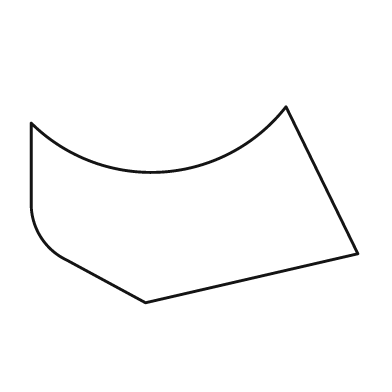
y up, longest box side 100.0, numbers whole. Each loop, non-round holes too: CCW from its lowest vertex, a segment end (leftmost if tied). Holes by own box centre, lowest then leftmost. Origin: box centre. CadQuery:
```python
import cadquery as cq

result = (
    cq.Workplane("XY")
    .moveTo(-15.0, -30.0)
    .lineTo(50.0, -15.0)
    .lineTo(28.0, 30.0)
    .threePointArc((-10.0, 10.0), (-50.0, 25.0))
    .lineTo(-50.0, 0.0)
    .threePointArc((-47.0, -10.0), (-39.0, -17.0))
    .close()
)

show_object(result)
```